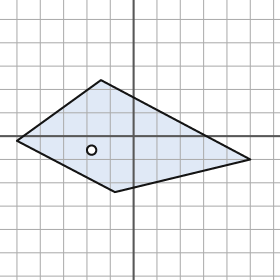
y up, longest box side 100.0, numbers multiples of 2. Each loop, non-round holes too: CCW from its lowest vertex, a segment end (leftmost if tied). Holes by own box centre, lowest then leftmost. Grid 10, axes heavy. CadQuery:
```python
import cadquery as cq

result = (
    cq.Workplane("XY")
    .moveTo(-8.0, -24.0)
    .lineTo(50.0, -10.0)
    .lineTo(-14.0, 24.0)
    .lineTo(-50.0, -2.0)
    .close()
    .moveTo(-18.0, -6.0)
    .circle(2.0)
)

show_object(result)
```